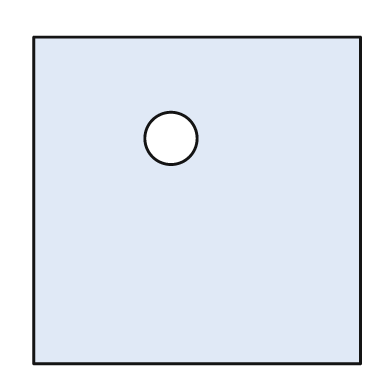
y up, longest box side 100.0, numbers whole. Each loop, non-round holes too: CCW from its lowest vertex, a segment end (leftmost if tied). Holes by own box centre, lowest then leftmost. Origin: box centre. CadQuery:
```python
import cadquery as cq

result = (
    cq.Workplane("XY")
    .moveTo(-50.0, -50.0)
    .lineTo(50.0, -50.0)
    .lineTo(50.0, 50.0)
    .lineTo(-50.0, 50.0)
    .close()
    .moveTo(-8.0, 19.0)
    .circle(8.0)
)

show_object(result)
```